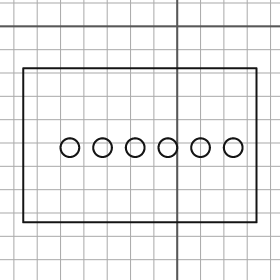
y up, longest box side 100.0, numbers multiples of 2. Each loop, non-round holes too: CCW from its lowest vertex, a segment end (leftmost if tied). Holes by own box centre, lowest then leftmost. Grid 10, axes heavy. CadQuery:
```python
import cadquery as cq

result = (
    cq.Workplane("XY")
    .moveTo(-66.0, -84.0)
    .lineTo(34.0, -84.0)
    .lineTo(34.0, -18.0)
    .lineTo(-66.0, -18.0)
    .close()
    .moveTo(-46.0, -52.0)
    .circle(4.0)
    .moveTo(-32.0, -52.0)
    .circle(4.0)
    .moveTo(-18.0, -52.0)
    .circle(4.0)
    .moveTo(-4.0, -52.0)
    .circle(4.0)
    .moveTo(10.0, -52.0)
    .circle(4.0)
    .moveTo(24.0, -52.0)
    .circle(4.0)
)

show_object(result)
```